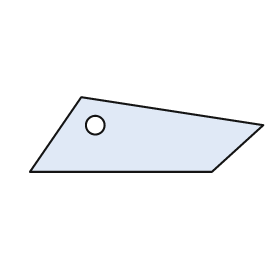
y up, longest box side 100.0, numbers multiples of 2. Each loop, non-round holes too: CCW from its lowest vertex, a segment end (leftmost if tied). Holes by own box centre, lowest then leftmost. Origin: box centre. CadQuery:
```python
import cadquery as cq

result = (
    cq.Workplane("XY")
    .moveTo(-50.0, -16.0)
    .lineTo(28.0, -16.0)
    .lineTo(50.0, 4.0)
    .lineTo(-28.0, 16.0)
    .close()
    .moveTo(-22.0, 4.0)
    .circle(4.0)
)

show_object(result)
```